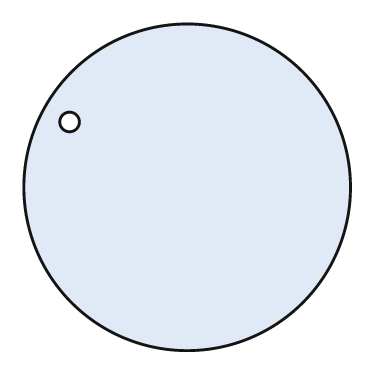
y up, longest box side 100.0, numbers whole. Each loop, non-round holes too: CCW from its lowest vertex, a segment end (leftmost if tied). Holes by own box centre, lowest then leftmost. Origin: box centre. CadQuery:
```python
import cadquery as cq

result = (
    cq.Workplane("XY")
    .moveTo(0.0, 0.0)
    .circle(50.0)
    .moveTo(-36.0, 20.0)
    .circle(3.0)
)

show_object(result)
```